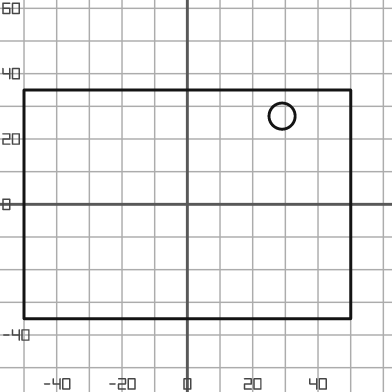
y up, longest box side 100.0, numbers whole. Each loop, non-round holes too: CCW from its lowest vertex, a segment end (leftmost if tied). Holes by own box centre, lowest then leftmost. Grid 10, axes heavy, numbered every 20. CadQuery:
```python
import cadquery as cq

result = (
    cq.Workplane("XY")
    .moveTo(-50.0, -35.0)
    .lineTo(50.0, -35.0)
    .lineTo(50.0, 35.0)
    .lineTo(-50.0, 35.0)
    .close()
    .moveTo(29.0, 27.0)
    .circle(4.0)
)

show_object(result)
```